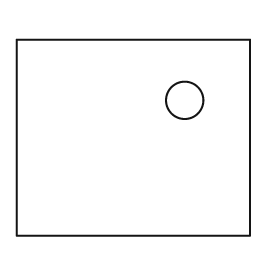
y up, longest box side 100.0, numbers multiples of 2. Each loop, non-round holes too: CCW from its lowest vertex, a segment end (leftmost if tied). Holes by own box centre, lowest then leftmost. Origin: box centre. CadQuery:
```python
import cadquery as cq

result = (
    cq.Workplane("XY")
    .moveTo(-50.0, -42.0)
    .lineTo(50.0, -42.0)
    .lineTo(50.0, 42.0)
    .lineTo(-50.0, 42.0)
    .close()
    .moveTo(22.0, 16.0)
    .circle(8.0)
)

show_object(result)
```